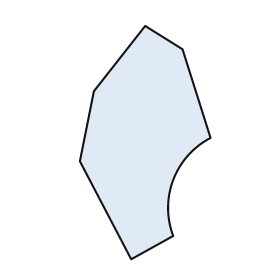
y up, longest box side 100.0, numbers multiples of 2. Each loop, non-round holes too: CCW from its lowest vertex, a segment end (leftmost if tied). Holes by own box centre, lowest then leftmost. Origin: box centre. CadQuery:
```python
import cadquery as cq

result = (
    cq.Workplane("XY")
    .moveTo(-6.0, -50.0)
    .lineTo(12.0, -40.0)
    .threePointArc((12.0, -16.0), (28.0, 2.0))
    .lineTo(16.0, 40.0)
    .lineTo(0.0, 50.0)
    .lineTo(-22.0, 22.0)
    .lineTo(-28.0, -8.0)
    .close()
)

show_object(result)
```